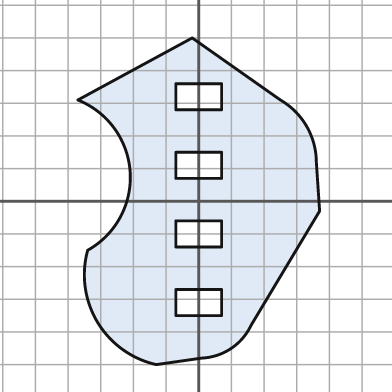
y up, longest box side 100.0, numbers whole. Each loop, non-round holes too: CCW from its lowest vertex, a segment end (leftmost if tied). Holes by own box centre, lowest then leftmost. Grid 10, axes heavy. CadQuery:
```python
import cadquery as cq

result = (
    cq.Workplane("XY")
    .moveTo(-13.0, -50.0)
    .lineTo(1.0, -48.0)
    .threePointArc((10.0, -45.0), (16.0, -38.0))
    .lineTo(37.0, -3.0)
    .lineTo(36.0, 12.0)
    .threePointArc((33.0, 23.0), (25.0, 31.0))
    .lineTo(-2.0, 50.0)
    .lineTo(-37.0, 31.0)
    .threePointArc((-21.0, 9.0), (-34.0, -15.0))
    .threePointArc((-31.0, -37.0), (-13.0, -50.0))
    .close()
    .moveTo(-7.0, -35.0)
    .lineTo(7.0, -35.0)
    .lineTo(7.0, -27.0)
    .lineTo(-7.0, -27.0)
    .close()
    .moveTo(-7.0, -14.0)
    .lineTo(7.0, -14.0)
    .lineTo(7.0, -6.0)
    .lineTo(-7.0, -6.0)
    .close()
    .moveTo(-7.0, 7.0)
    .lineTo(7.0, 7.0)
    .lineTo(7.0, 15.0)
    .lineTo(-7.0, 15.0)
    .close()
    .moveTo(-7.0, 28.0)
    .lineTo(7.0, 28.0)
    .lineTo(7.0, 36.0)
    .lineTo(-7.0, 36.0)
    .close()
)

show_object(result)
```